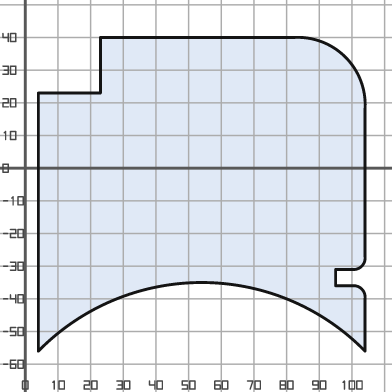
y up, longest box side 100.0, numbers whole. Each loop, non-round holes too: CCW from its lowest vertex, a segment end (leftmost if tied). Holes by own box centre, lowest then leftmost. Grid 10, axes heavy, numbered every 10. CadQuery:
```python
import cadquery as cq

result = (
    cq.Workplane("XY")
    .moveTo(4.0, -56.0)
    .threePointArc((54.0, -35.0), (104.0, -56.0))
    .lineTo(104.0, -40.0)
    .threePointArc((103.0, -37.0), (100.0, -36.0))
    .lineTo(95.0, -36.0)
    .lineTo(95.0, -31.0)
    .lineTo(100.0, -31.0)
    .threePointArc((103.0, -30.0), (104.0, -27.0))
    .lineTo(104.0, 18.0)
    .threePointArc((98.0, 34.0), (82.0, 40.0))
    .lineTo(23.0, 40.0)
    .lineTo(23.0, 23.0)
    .lineTo(4.0, 23.0)
    .close()
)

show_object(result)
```